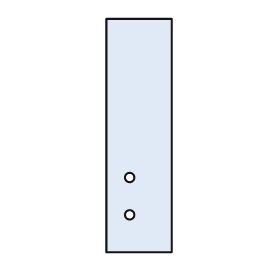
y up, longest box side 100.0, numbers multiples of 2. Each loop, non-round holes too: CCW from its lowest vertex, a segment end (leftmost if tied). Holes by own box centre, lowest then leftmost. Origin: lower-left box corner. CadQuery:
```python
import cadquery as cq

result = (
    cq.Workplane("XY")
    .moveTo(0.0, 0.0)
    .lineTo(28.0, 0.0)
    .lineTo(28.0, 100.0)
    .lineTo(0.0, 100.0)
    .close()
    .moveTo(10.0, 16.0)
    .circle(2.0)
    .moveTo(10.0, 32.0)
    .circle(2.0)
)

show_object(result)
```